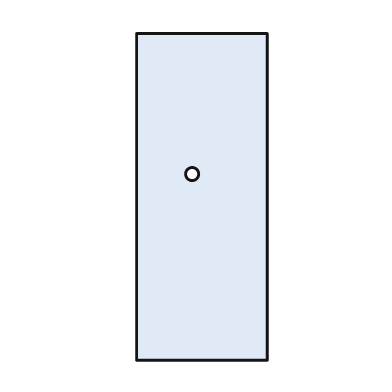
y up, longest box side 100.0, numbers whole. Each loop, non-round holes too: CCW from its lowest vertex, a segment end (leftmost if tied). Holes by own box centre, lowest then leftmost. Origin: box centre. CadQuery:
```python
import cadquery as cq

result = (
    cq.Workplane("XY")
    .moveTo(-20.0, -50.0)
    .lineTo(20.0, -50.0)
    .lineTo(20.0, 50.0)
    .lineTo(-20.0, 50.0)
    .close()
    .moveTo(-3.0, 7.0)
    .circle(2.0)
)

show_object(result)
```